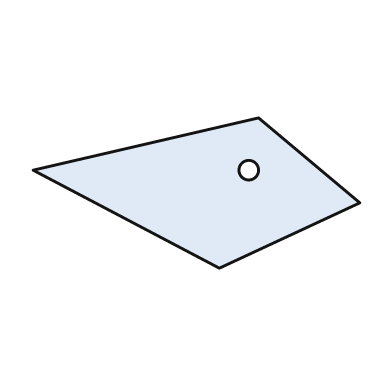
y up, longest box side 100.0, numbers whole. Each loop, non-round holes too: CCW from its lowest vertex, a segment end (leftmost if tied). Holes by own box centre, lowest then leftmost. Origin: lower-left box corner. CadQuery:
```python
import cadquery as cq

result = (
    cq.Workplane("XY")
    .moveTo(57.0, 0.0)
    .lineTo(100.0, 20.0)
    .lineTo(69.0, 46.0)
    .lineTo(0.0, 30.0)
    .close()
    .moveTo(66.0, 30.0)
    .circle(3.0)
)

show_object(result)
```